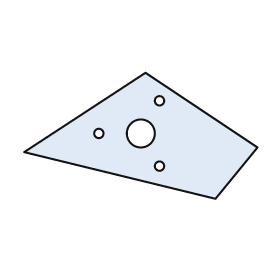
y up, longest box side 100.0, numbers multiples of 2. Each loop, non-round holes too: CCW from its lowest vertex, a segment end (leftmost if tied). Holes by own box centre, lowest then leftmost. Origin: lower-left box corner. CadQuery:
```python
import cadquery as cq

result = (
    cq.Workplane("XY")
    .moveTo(82.0, 0.0)
    .lineTo(100.0, 22.0)
    .lineTo(52.0, 54.0)
    .lineTo(0.0, 20.0)
    .close()
    .moveTo(58.0, 14.0)
    .circle(2.0)
    .moveTo(32.0, 28.0)
    .circle(2.0)
    .moveTo(50.0, 28.0)
    .circle(6.0)
    .moveTo(58.0, 42.0)
    .circle(2.0)
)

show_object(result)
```